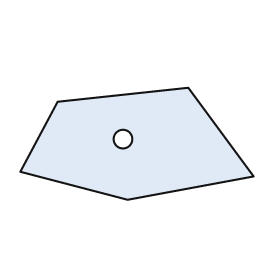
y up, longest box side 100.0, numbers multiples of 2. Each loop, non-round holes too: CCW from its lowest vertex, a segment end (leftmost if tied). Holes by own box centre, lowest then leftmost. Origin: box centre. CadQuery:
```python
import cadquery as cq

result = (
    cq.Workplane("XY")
    .moveTo(-4.0, -24.0)
    .lineTo(50.0, -14.0)
    .lineTo(22.0, 24.0)
    .lineTo(-34.0, 18.0)
    .lineTo(-50.0, -12.0)
    .close()
    .moveTo(-6.0, 2.0)
    .circle(4.0)
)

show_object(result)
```